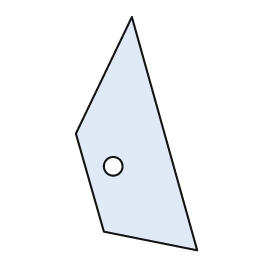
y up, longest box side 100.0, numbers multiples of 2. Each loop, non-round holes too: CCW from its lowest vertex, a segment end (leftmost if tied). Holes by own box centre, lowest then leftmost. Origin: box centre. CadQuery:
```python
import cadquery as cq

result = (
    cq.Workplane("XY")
    .moveTo(26.0, -50.0)
    .lineTo(-2.0, 50.0)
    .lineTo(-26.0, 0.0)
    .lineTo(-14.0, -42.0)
    .close()
    .moveTo(-10.0, -14.0)
    .circle(4.0)
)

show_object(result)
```